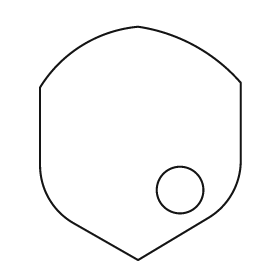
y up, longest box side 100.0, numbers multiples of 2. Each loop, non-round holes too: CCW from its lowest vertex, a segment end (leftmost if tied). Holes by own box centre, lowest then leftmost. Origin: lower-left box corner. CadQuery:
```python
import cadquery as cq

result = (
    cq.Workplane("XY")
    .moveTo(42.0, 0.0)
    .lineTo(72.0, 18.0)
    .threePointArc((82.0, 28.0), (86.0, 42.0))
    .lineTo(86.0, 76.0)
    .threePointArc((66.0, 92.0), (42.0, 100.0))
    .threePointArc((18.0, 92.0), (0.0, 74.0))
    .lineTo(0.0, 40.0)
    .threePointArc((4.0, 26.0), (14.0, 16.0))
    .close()
    .moveTo(60.0, 30.0)
    .circle(10.0)
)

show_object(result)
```